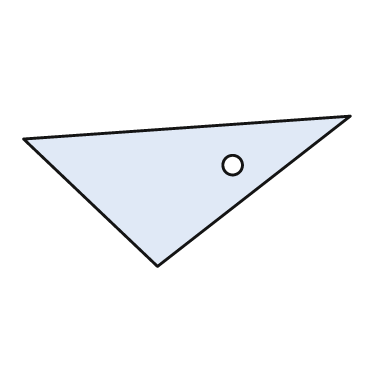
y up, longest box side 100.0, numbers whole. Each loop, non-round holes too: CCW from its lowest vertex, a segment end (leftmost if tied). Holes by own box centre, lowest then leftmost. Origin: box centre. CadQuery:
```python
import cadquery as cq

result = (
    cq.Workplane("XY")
    .moveTo(-9.0, -23.0)
    .lineTo(50.0, 23.0)
    .lineTo(-50.0, 16.0)
    .close()
    .moveTo(14.0, 8.0)
    .circle(3.0)
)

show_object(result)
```